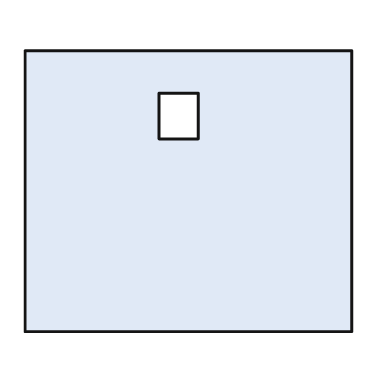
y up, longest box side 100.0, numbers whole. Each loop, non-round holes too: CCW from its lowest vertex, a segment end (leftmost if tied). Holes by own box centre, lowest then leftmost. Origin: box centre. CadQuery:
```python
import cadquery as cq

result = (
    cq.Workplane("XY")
    .moveTo(-50.0, -43.0)
    .lineTo(50.0, -43.0)
    .lineTo(50.0, 43.0)
    .lineTo(-50.0, 43.0)
    .close()
    .moveTo(-9.0, 16.0)
    .lineTo(3.0, 16.0)
    .lineTo(3.0, 30.0)
    .lineTo(-9.0, 30.0)
    .close()
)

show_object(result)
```